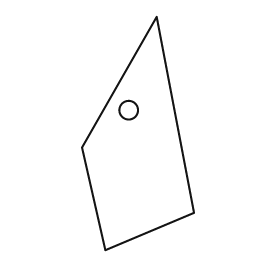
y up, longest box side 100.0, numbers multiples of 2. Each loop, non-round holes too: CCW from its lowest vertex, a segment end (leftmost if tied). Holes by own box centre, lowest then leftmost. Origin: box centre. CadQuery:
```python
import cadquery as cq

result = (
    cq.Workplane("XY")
    .moveTo(-14.0, -50.0)
    .lineTo(24.0, -34.0)
    .lineTo(8.0, 50.0)
    .lineTo(-24.0, -6.0)
    .close()
    .moveTo(-4.0, 10.0)
    .circle(4.0)
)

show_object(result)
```